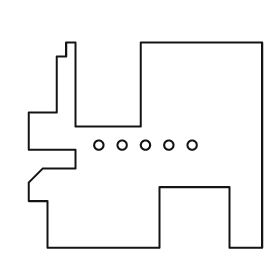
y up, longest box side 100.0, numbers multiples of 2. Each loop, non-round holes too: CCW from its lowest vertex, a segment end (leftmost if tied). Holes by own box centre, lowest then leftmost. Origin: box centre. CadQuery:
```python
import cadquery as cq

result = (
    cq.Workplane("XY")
    .moveTo(-42.0, -44.0)
    .lineTo(6.0, -44.0)
    .lineTo(6.0, -18.0)
    .lineTo(36.0, -18.0)
    .lineTo(36.0, -44.0)
    .lineTo(50.0, -44.0)
    .lineTo(50.0, 44.0)
    .lineTo(-2.0, 44.0)
    .lineTo(-2.0, 8.0)
    .lineTo(-30.0, 8.0)
    .lineTo(-30.0, 44.0)
    .lineTo(-34.0, 44.0)
    .lineTo(-34.0, 38.0)
    .lineTo(-38.0, 38.0)
    .lineTo(-38.0, 14.0)
    .lineTo(-50.0, 14.0)
    .lineTo(-50.0, -2.0)
    .lineTo(-30.0, -2.0)
    .lineTo(-30.0, -10.0)
    .lineTo(-44.0, -10.0)
    .lineTo(-50.0, -16.0)
    .lineTo(-50.0, -24.0)
    .lineTo(-42.0, -24.0)
    .close()
    .moveTo(-20.0, 0.0)
    .circle(2.0)
    .moveTo(-10.0, 0.0)
    .circle(2.0)
    .moveTo(0.0, 0.0)
    .circle(2.0)
    .moveTo(10.0, 0.0)
    .circle(2.0)
    .moveTo(20.0, 0.0)
    .circle(2.0)
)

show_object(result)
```